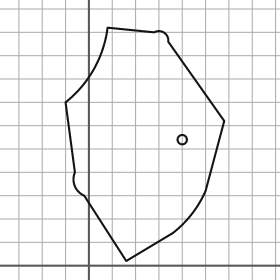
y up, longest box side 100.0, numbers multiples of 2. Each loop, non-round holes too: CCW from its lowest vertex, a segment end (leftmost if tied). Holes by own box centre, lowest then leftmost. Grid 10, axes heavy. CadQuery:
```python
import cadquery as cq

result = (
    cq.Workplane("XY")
    .moveTo(16.0, 2.0)
    .lineTo(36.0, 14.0)
    .threePointArc((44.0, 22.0), (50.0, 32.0))
    .lineTo(58.0, 62.0)
    .lineTo(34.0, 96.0)
    .threePointArc((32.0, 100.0), (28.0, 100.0))
    .lineTo(8.0, 102.0)
    .threePointArc((2.0, 84.0), (-10.0, 70.0))
    .lineTo(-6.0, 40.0)
    .threePointArc((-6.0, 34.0), (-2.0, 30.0))
    .close()
    .moveTo(40.0, 54.0)
    .circle(2.0)
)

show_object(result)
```